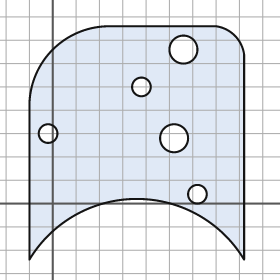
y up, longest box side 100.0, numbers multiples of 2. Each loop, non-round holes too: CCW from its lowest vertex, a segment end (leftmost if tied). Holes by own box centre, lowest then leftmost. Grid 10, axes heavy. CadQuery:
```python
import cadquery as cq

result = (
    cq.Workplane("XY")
    .moveTo(-10.0, -24.0)
    .threePointArc((36.0, 2.0), (82.0, -24.0))
    .lineTo(82.0, 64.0)
    .threePointArc((78.0, 72.0), (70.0, 76.0))
    .lineTo(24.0, 76.0)
    .threePointArc((0.0, 66.0), (-10.0, 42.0))
    .close()
    .moveTo(62.0, 4.0)
    .circle(4.0)
    .moveTo(52.0, 28.0)
    .circle(6.0)
    .moveTo(-2.0, 30.0)
    .circle(4.0)
    .moveTo(38.0, 50.0)
    .circle(4.0)
    .moveTo(56.0, 66.0)
    .circle(6.0)
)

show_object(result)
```